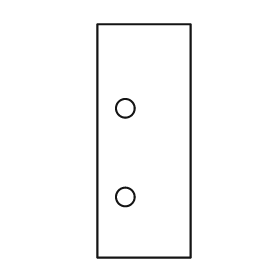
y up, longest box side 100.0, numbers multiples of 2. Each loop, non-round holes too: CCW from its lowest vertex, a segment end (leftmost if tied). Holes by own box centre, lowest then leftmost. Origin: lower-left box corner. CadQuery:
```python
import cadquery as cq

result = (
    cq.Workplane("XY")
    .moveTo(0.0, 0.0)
    .lineTo(40.0, 0.0)
    .lineTo(40.0, 100.0)
    .lineTo(0.0, 100.0)
    .close()
    .moveTo(12.0, 26.0)
    .circle(4.0)
    .moveTo(12.0, 64.0)
    .circle(4.0)
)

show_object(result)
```